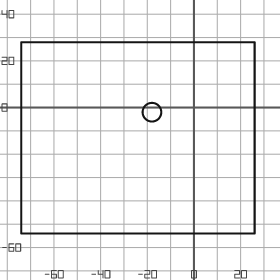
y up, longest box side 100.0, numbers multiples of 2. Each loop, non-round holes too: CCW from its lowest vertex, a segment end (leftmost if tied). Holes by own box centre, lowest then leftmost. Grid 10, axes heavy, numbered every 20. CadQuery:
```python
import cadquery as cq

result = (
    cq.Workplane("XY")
    .moveTo(-74.0, -54.0)
    .lineTo(26.0, -54.0)
    .lineTo(26.0, 28.0)
    .lineTo(-74.0, 28.0)
    .close()
    .moveTo(-18.0, -2.0)
    .circle(4.0)
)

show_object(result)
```